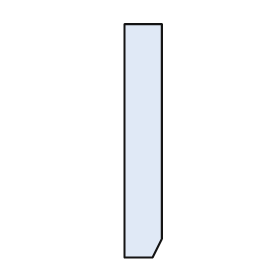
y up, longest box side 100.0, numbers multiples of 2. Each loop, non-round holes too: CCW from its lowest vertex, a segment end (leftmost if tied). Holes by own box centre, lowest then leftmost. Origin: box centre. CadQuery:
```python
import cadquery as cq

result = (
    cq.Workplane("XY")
    .moveTo(-8.0, -50.0)
    .lineTo(4.0, -50.0)
    .lineTo(8.0, -42.0)
    .lineTo(8.0, 50.0)
    .lineTo(-8.0, 50.0)
    .close()
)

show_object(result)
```